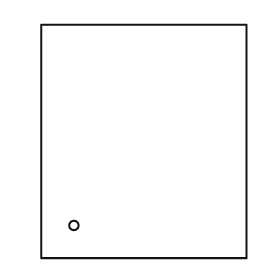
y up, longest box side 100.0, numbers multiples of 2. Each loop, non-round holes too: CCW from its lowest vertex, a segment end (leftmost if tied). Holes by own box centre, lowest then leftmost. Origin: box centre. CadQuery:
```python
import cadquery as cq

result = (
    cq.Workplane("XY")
    .moveTo(-44.0, -50.0)
    .lineTo(44.0, -50.0)
    .lineTo(44.0, 50.0)
    .lineTo(-44.0, 50.0)
    .close()
    .moveTo(-30.0, -36.0)
    .circle(2.0)
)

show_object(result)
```